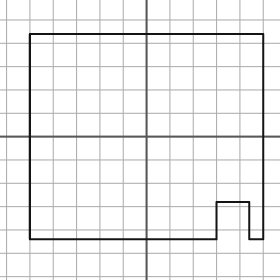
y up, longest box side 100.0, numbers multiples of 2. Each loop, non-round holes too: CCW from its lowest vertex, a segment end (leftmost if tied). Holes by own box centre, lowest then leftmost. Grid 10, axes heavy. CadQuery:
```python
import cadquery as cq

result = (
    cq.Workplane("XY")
    .moveTo(-50.0, -44.0)
    .lineTo(30.0, -44.0)
    .lineTo(30.0, -28.0)
    .lineTo(44.0, -28.0)
    .lineTo(44.0, -44.0)
    .lineTo(50.0, -44.0)
    .lineTo(50.0, 44.0)
    .lineTo(-50.0, 44.0)
    .close()
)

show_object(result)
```